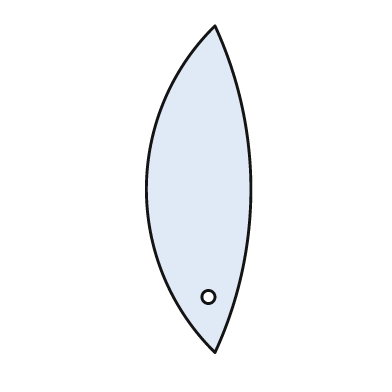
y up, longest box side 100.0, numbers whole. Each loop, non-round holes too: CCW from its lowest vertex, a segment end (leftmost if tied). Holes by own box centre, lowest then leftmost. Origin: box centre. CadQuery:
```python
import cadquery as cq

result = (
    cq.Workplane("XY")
    .moveTo(5.0, -50.0)
    .threePointArc((16.0, 0.0), (5.0, 50.0))
    .threePointArc((-16.0, 0.0), (5.0, -50.0))
    .close()
    .moveTo(3.0, -33.0)
    .circle(2.0)
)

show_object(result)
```